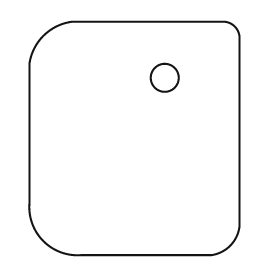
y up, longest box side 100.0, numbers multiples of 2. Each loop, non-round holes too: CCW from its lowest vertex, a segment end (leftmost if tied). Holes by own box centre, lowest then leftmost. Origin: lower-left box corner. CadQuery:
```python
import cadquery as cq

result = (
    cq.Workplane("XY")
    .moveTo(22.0, 0.0)
    .lineTo(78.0, 0.0)
    .threePointArc((86.0, 4.0), (90.0, 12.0))
    .lineTo(90.0, 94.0)
    .threePointArc((88.0, 98.0), (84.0, 100.0))
    .lineTo(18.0, 100.0)
    .threePointArc((6.0, 94.0), (0.0, 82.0))
    .lineTo(0.0, 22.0)
    .threePointArc((6.0, 6.0), (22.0, 0.0))
    .close()
    .moveTo(58.0, 76.0)
    .circle(6.0)
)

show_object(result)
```